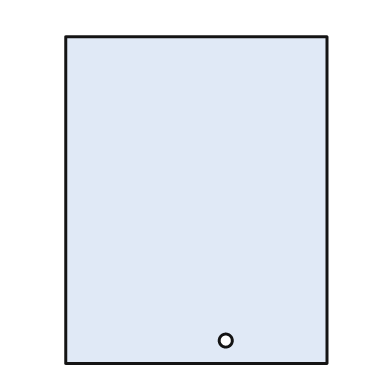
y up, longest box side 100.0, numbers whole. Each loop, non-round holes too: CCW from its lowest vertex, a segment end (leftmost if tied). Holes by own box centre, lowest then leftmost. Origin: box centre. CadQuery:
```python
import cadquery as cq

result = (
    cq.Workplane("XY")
    .moveTo(-40.0, -50.0)
    .lineTo(40.0, -50.0)
    .lineTo(40.0, 50.0)
    .lineTo(-40.0, 50.0)
    .close()
    .moveTo(9.0, -43.0)
    .circle(2.0)
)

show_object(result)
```